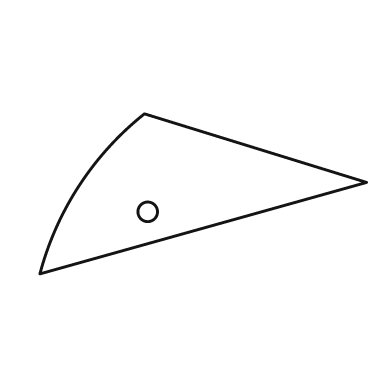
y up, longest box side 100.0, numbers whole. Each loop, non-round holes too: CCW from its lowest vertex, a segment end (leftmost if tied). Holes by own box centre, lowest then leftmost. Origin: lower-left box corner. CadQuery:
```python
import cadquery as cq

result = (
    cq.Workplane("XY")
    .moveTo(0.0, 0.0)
    .lineTo(100.0, 28.0)
    .lineTo(32.0, 49.0)
    .threePointArc((12.0, 27.0), (0.0, 0.0))
    .close()
    .moveTo(33.0, 19.0)
    .circle(3.0)
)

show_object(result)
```